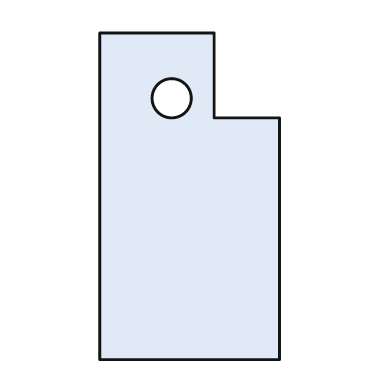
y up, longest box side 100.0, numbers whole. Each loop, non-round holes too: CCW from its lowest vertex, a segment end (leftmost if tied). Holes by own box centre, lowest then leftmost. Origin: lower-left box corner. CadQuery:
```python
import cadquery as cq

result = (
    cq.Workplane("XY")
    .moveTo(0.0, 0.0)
    .lineTo(55.0, 0.0)
    .lineTo(55.0, 74.0)
    .lineTo(35.0, 74.0)
    .lineTo(35.0, 100.0)
    .lineTo(0.0, 100.0)
    .close()
    .moveTo(22.0, 80.0)
    .circle(6.0)
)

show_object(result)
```